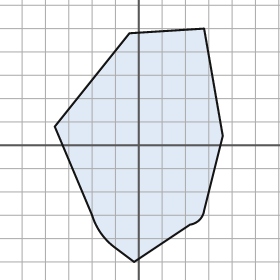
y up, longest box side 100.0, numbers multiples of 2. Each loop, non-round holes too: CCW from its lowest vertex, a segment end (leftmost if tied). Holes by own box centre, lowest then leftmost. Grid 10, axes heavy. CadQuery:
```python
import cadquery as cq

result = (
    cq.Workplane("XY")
    .moveTo(-2.0, -50.0)
    .lineTo(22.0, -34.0)
    .threePointArc((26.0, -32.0), (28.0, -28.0))
    .lineTo(36.0, 4.0)
    .lineTo(28.0, 50.0)
    .lineTo(-4.0, 48.0)
    .lineTo(-36.0, 8.0)
    .lineTo(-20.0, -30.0)
    .threePointArc((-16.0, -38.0), (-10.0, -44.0))
    .close()
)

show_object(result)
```